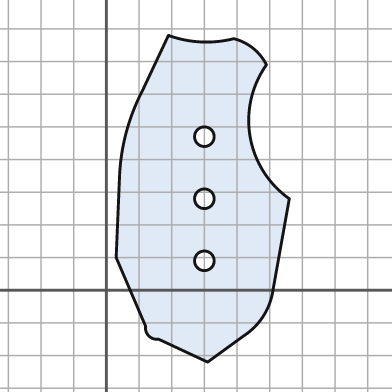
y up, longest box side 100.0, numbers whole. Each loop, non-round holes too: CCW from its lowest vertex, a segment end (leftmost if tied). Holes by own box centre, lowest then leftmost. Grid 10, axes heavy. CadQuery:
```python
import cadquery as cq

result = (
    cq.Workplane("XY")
    .moveTo(31.0, -22.0)
    .lineTo(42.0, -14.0)
    .threePointArc((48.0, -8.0), (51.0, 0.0))
    .lineTo(56.0, 28.0)
    .threePointArc((44.0, 47.0), (49.0, 69.0))
    .threePointArc((45.0, 74.0), (39.0, 77.0))
    .threePointArc((29.0, 76.0), (19.0, 78.0))
    .lineTo(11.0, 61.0)
    .threePointArc((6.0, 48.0), (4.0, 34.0))
    .lineTo(3.0, 10.0)
    .lineTo(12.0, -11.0)
    .threePointArc((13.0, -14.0), (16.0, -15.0))
    .close()
    .moveTo(30.0, 9.0)
    .circle(3.0)
    .moveTo(30.0, 28.0)
    .circle(3.0)
    .moveTo(30.0, 47.0)
    .circle(3.0)
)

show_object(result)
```